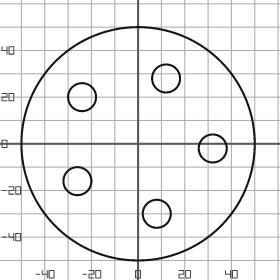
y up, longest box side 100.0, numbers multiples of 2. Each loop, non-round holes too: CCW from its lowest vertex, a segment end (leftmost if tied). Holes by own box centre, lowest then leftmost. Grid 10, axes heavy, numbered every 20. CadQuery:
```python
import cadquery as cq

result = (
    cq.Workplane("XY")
    .moveTo(0.0, 0.0)
    .circle(50.0)
    .moveTo(8.0, -30.0)
    .circle(6.0)
    .moveTo(-26.0, -16.0)
    .circle(6.0)
    .moveTo(32.0, -2.0)
    .circle(6.0)
    .moveTo(-24.0, 20.0)
    .circle(6.0)
    .moveTo(12.0, 28.0)
    .circle(6.0)
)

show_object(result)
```